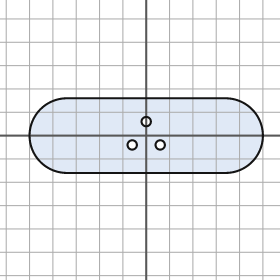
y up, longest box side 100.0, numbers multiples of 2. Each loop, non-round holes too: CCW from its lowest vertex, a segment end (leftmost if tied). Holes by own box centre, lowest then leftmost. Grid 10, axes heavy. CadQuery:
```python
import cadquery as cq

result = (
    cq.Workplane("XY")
    .moveTo(-34.0, -16.0)
    .lineTo(34.0, -16.0)
    .threePointArc((50.0, 0.0), (34.0, 16.0))
    .lineTo(-34.0, 16.0)
    .threePointArc((-50.0, 0.0), (-34.0, -16.0))
    .close()
    .moveTo(-6.0, -4.0)
    .circle(2.0)
    .moveTo(6.0, -4.0)
    .circle(2.0)
    .moveTo(0.0, 6.0)
    .circle(2.0)
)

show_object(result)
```